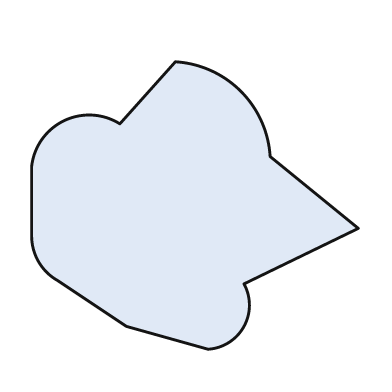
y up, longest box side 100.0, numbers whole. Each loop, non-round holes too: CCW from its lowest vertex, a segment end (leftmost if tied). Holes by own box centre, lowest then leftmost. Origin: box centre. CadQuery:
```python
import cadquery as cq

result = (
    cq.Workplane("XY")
    .moveTo(4.0, -44.0)
    .threePointArc((15.0, -37.0), (15.0, -24.0))
    .lineTo(50.0, -7.0)
    .lineTo(23.0, 15.0)
    .threePointArc((14.0, 35.0), (-6.0, 44.0))
    .lineTo(-23.0, 25.0)
    .threePointArc((-40.0, 26.0), (-50.0, 12.0))
    .lineTo(-50.0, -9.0)
    .threePointArc((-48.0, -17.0), (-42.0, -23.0))
    .lineTo(-21.0, -37.0)
    .close()
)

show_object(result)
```